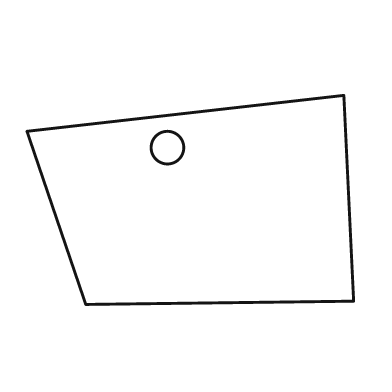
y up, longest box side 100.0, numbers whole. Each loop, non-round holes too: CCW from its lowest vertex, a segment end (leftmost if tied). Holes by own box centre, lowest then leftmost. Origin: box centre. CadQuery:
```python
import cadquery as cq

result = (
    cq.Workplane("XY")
    .moveTo(-32.0, -32.0)
    .lineTo(50.0, -31.0)
    .lineTo(47.0, 32.0)
    .lineTo(-50.0, 21.0)
    .close()
    .moveTo(-7.0, 16.0)
    .circle(5.0)
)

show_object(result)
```